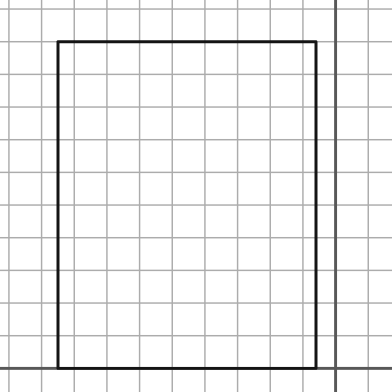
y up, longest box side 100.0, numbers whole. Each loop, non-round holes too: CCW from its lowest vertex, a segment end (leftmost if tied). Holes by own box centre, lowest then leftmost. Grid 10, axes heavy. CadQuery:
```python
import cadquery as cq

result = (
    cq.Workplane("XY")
    .moveTo(-85.0, 0.0)
    .lineTo(-6.0, 0.0)
    .lineTo(-6.0, 100.0)
    .lineTo(-85.0, 100.0)
    .close()
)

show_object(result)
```